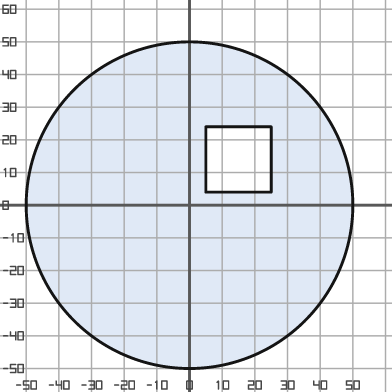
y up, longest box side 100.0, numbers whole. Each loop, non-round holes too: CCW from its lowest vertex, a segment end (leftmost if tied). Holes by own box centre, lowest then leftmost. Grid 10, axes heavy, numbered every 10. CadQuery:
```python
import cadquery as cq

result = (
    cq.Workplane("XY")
    .moveTo(0.0, 0.0)
    .circle(50.0)
    .moveTo(5.0, 4.0)
    .lineTo(25.0, 4.0)
    .lineTo(25.0, 24.0)
    .lineTo(5.0, 24.0)
    .close()
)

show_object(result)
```